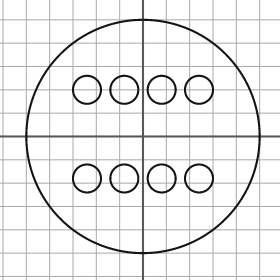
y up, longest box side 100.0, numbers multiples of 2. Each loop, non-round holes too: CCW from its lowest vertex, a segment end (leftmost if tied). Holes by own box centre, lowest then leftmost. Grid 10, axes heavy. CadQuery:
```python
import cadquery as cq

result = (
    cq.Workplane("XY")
    .moveTo(0.0, 0.0)
    .circle(50.0)
    .moveTo(-24.0, -18.0)
    .circle(6.0)
    .moveTo(-8.0, -18.0)
    .circle(6.0)
    .moveTo(8.0, -18.0)
    .circle(6.0)
    .moveTo(24.0, -18.0)
    .circle(6.0)
    .moveTo(-24.0, 20.0)
    .circle(6.0)
    .moveTo(-8.0, 20.0)
    .circle(6.0)
    .moveTo(8.0, 20.0)
    .circle(6.0)
    .moveTo(24.0, 20.0)
    .circle(6.0)
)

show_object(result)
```